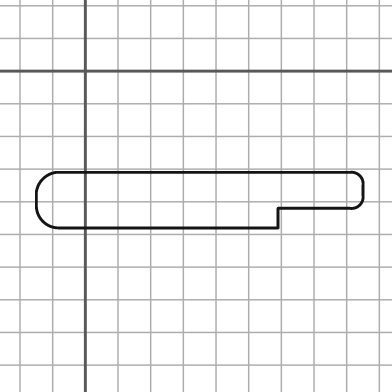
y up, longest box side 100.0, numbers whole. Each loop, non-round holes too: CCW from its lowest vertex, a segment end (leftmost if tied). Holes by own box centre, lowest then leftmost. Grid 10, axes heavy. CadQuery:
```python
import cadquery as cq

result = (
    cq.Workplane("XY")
    .moveTo(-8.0, -48.0)
    .lineTo(59.0, -48.0)
    .lineTo(59.0, -42.0)
    .lineTo(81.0, -42.0)
    .threePointArc((84.0, -41.0), (85.0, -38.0))
    .lineTo(85.0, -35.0)
    .threePointArc((84.0, -32.0), (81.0, -31.0))
    .lineTo(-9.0, -31.0)
    .threePointArc((-13.0, -33.0), (-15.0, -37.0))
    .lineTo(-15.0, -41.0)
    .threePointArc((-13.0, -46.0), (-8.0, -48.0))
    .close()
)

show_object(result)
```